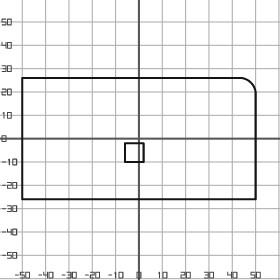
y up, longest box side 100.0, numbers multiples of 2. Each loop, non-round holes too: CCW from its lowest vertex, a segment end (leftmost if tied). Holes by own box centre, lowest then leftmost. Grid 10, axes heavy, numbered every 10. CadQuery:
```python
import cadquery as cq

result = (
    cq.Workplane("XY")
    .moveTo(-50.0, -26.0)
    .lineTo(50.0, -26.0)
    .lineTo(50.0, 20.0)
    .threePointArc((48.0, 24.0), (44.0, 26.0))
    .lineTo(-50.0, 26.0)
    .close()
    .moveTo(-6.0, -10.0)
    .lineTo(2.0, -10.0)
    .lineTo(2.0, -2.0)
    .lineTo(-6.0, -2.0)
    .close()
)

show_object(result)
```